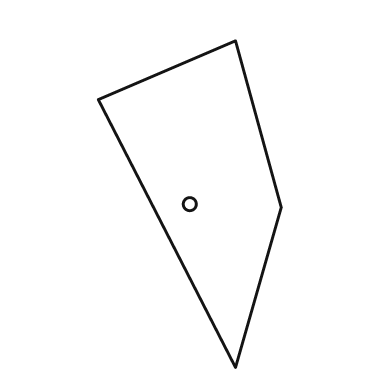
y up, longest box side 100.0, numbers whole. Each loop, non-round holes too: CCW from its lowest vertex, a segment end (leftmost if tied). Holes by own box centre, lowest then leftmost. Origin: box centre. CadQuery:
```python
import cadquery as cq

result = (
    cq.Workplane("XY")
    .moveTo(14.0, -50.0)
    .lineTo(28.0, -1.0)
    .lineTo(14.0, 50.0)
    .lineTo(-28.0, 32.0)
    .close()
    .moveTo(0.0, 0.0)
    .circle(2.0)
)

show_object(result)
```